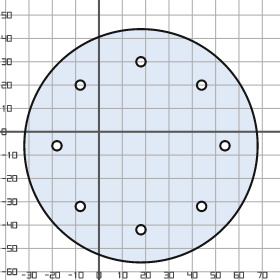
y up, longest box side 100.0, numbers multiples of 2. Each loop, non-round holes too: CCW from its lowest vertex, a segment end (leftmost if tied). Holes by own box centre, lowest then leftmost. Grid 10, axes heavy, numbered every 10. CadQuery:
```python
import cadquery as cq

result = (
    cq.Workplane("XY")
    .moveTo(18.0, -6.0)
    .circle(50.0)
    .moveTo(18.0, -42.0)
    .circle(2.0)
    .moveTo(-8.0, -32.0)
    .circle(2.0)
    .moveTo(44.0, -32.0)
    .circle(2.0)
    .moveTo(-18.0, -6.0)
    .circle(2.0)
    .moveTo(54.0, -6.0)
    .circle(2.0)
    .moveTo(-8.0, 20.0)
    .circle(2.0)
    .moveTo(44.0, 20.0)
    .circle(2.0)
    .moveTo(18.0, 30.0)
    .circle(2.0)
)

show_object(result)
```